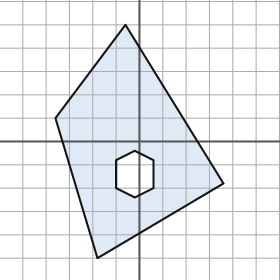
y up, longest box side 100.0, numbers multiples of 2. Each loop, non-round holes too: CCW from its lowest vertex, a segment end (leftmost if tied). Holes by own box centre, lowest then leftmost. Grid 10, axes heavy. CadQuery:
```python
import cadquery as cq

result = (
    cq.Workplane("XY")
    .moveTo(-18.0, -50.0)
    .lineTo(36.0, -18.0)
    .lineTo(-6.0, 50.0)
    .lineTo(-36.0, 10.0)
    .close()
    .moveTo(-2.0, -24.0)
    .lineTo(6.0, -20.0)
    .lineTo(6.0, -8.0)
    .lineTo(-2.0, -4.0)
    .lineTo(-10.0, -8.0)
    .lineTo(-10.0, -20.0)
    .close()
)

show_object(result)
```